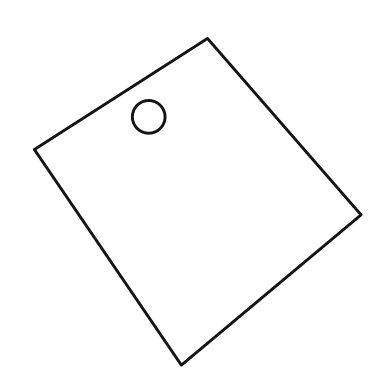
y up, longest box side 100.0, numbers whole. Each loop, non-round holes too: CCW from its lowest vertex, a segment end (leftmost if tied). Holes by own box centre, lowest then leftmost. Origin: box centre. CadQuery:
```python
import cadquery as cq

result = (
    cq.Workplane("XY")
    .moveTo(-5.0, -50.0)
    .lineTo(50.0, -4.0)
    .lineTo(3.0, 50.0)
    .lineTo(-50.0, 16.0)
    .close()
    .moveTo(-15.0, 26.0)
    .circle(5.0)
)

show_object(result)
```